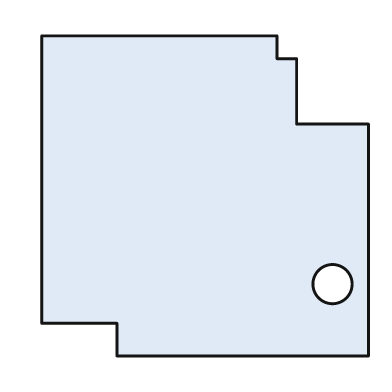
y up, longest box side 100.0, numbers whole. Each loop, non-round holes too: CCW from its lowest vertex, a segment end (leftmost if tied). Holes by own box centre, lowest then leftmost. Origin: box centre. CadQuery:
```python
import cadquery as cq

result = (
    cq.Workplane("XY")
    .moveTo(-27.0, -49.0)
    .lineTo(50.0, -49.0)
    .lineTo(50.0, 22.0)
    .lineTo(28.0, 22.0)
    .lineTo(28.0, 42.0)
    .lineTo(22.0, 42.0)
    .lineTo(22.0, 49.0)
    .lineTo(-50.0, 49.0)
    .lineTo(-50.0, -39.0)
    .lineTo(-27.0, -39.0)
    .close()
    .moveTo(39.0, -27.0)
    .circle(6.0)
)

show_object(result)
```